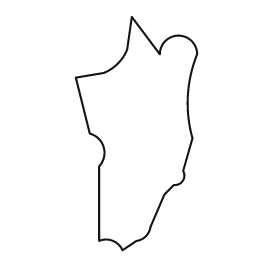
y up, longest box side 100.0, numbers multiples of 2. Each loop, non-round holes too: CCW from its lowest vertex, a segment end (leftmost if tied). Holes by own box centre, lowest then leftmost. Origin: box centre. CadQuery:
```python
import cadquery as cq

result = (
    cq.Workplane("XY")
    .moveTo(-6.0, -50.0)
    .lineTo(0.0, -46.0)
    .threePointArc((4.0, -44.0), (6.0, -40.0))
    .lineTo(12.0, -26.0)
    .lineTo(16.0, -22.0)
    .threePointArc((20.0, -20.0), (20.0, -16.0))
    .lineTo(24.0, -2.0)
    .threePointArc((22.0, 16.0), (26.0, 34.0))
    .threePointArc((18.0, 42.0), (10.0, 34.0))
    .lineTo(-2.0, 50.0)
    .lineTo(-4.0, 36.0)
    .threePointArc((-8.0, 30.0), (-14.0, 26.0))
    .lineTo(-26.0, 24.0)
    .lineTo(-20.0, 0.0)
    .threePointArc((-14.0, -6.0), (-16.0, -14.0))
    .lineTo(-16.0, -46.0)
    .threePointArc((-10.0, -46.0), (-6.0, -50.0))
    .close()
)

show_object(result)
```